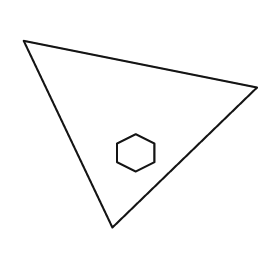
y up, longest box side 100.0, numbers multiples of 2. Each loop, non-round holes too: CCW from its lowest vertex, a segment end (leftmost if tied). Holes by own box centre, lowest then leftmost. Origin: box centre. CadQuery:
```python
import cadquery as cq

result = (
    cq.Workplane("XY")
    .moveTo(-12.0, -40.0)
    .lineTo(50.0, 20.0)
    .lineTo(-50.0, 40.0)
    .close()
    .moveTo(-2.0, -16.0)
    .lineTo(6.0, -12.0)
    .lineTo(6.0, -4.0)
    .lineTo(-2.0, 0.0)
    .lineTo(-10.0, -4.0)
    .lineTo(-10.0, -12.0)
    .close()
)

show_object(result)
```